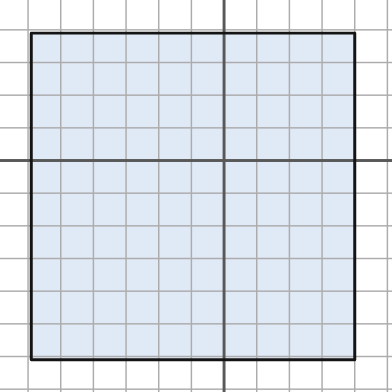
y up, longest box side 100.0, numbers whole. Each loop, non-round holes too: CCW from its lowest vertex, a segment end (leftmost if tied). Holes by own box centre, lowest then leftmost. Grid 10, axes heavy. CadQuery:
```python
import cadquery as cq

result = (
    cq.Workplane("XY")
    .moveTo(-59.0, -61.0)
    .lineTo(40.0, -61.0)
    .lineTo(40.0, 39.0)
    .lineTo(-59.0, 39.0)
    .close()
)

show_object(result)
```